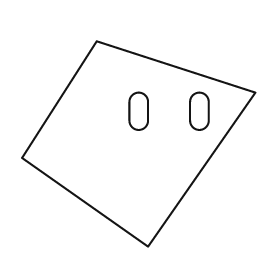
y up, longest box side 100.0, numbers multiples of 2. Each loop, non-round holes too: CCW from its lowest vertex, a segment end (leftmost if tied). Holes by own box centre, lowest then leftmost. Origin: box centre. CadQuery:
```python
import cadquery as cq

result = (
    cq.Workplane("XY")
    .moveTo(4.0, -44.0)
    .lineTo(50.0, 22.0)
    .lineTo(-18.0, 44.0)
    .lineTo(-50.0, -6.0)
    .close()
    .moveTo(-4.0, 10.0)
    .threePointArc((0.0, 6.0), (4.0, 10.0))
    .lineTo(4.0, 18.0)
    .threePointArc((0.0, 22.0), (-4.0, 18.0))
    .close()
    .moveTo(22.0, 10.0)
    .threePointArc((26.0, 6.0), (30.0, 10.0))
    .lineTo(30.0, 18.0)
    .threePointArc((26.0, 22.0), (22.0, 18.0))
    .close()
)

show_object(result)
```